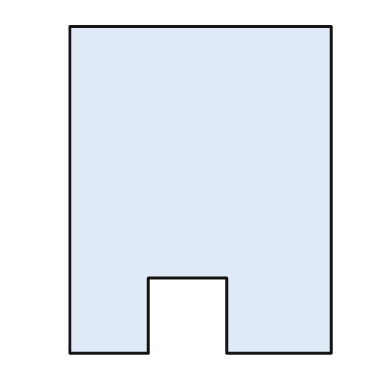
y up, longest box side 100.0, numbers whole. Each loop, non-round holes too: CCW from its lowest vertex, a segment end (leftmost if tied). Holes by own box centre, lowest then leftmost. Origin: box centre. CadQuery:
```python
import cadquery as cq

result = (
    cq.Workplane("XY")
    .moveTo(-40.0, -50.0)
    .lineTo(-16.0, -50.0)
    .lineTo(-16.0, -27.0)
    .lineTo(8.0, -27.0)
    .lineTo(8.0, -50.0)
    .lineTo(40.0, -50.0)
    .lineTo(40.0, 50.0)
    .lineTo(-40.0, 50.0)
    .close()
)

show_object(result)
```